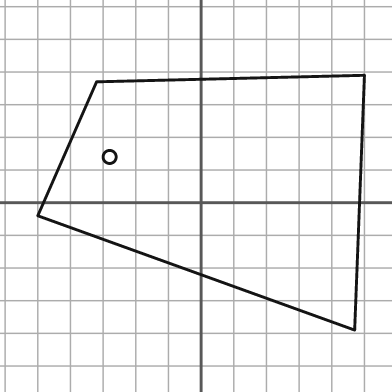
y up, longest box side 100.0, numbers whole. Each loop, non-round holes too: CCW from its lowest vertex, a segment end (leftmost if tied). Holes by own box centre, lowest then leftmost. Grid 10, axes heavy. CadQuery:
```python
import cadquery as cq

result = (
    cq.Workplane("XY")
    .moveTo(47.0, -39.0)
    .lineTo(50.0, 39.0)
    .lineTo(-32.0, 37.0)
    .lineTo(-50.0, -4.0)
    .close()
    .moveTo(-28.0, 14.0)
    .circle(2.0)
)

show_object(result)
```